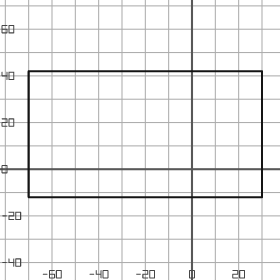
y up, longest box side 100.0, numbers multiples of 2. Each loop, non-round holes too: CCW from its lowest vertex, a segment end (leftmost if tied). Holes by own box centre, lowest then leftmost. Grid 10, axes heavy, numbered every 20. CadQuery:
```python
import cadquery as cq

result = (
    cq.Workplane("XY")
    .moveTo(-70.0, -12.0)
    .lineTo(30.0, -12.0)
    .lineTo(30.0, 42.0)
    .lineTo(-70.0, 42.0)
    .close()
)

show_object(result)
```